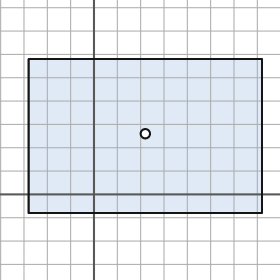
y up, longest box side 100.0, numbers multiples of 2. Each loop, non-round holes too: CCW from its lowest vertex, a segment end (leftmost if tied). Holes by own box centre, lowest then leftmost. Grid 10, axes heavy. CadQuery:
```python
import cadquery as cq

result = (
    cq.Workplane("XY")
    .moveTo(-28.0, -8.0)
    .lineTo(72.0, -8.0)
    .lineTo(72.0, 58.0)
    .lineTo(-28.0, 58.0)
    .close()
    .moveTo(22.0, 26.0)
    .circle(2.0)
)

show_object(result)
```